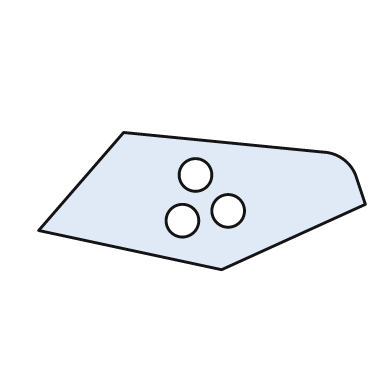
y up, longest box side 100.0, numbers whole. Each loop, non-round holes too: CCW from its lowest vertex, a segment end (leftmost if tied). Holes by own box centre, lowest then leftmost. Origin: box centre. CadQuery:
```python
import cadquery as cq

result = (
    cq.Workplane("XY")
    .moveTo(6.0, -21.0)
    .lineTo(50.0, -1.0)
    .lineTo(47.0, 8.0)
    .threePointArc((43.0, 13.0), (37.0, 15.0))
    .lineTo(-24.0, 21.0)
    .lineTo(-50.0, -9.0)
    .close()
    .moveTo(-6.0, -6.0)
    .circle(5.0)
    .moveTo(8.0, -3.0)
    .circle(5.0)
    .moveTo(-2.0, 8.0)
    .circle(5.0)
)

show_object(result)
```